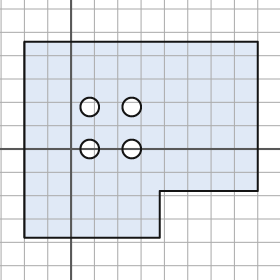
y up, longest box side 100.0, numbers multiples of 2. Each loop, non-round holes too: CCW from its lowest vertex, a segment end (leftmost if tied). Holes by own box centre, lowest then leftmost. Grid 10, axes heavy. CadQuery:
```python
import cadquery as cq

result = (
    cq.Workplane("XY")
    .moveTo(-20.0, -38.0)
    .lineTo(38.0, -38.0)
    .lineTo(38.0, -18.0)
    .lineTo(80.0, -18.0)
    .lineTo(80.0, 46.0)
    .lineTo(-20.0, 46.0)
    .close()
    .moveTo(8.0, 0.0)
    .circle(4.0)
    .moveTo(26.0, 0.0)
    .circle(4.0)
    .moveTo(8.0, 18.0)
    .circle(4.0)
    .moveTo(26.0, 18.0)
    .circle(4.0)
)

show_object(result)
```